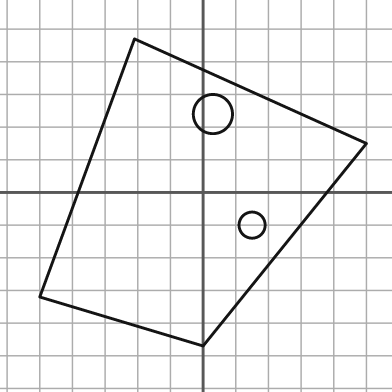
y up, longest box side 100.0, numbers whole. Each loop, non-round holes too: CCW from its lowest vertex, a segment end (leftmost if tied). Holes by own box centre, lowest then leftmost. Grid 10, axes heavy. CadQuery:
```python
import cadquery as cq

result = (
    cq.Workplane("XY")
    .moveTo(0.0, -47.0)
    .lineTo(50.0, 15.0)
    .lineTo(-21.0, 47.0)
    .lineTo(-50.0, -32.0)
    .close()
    .moveTo(15.0, -10.0)
    .circle(4.0)
    .moveTo(3.0, 24.0)
    .circle(6.0)
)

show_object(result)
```